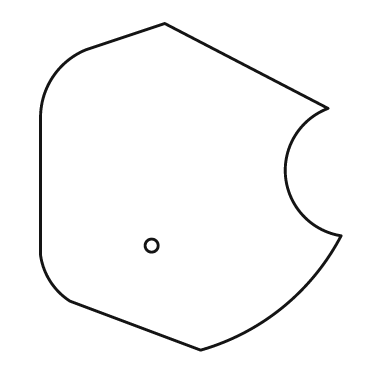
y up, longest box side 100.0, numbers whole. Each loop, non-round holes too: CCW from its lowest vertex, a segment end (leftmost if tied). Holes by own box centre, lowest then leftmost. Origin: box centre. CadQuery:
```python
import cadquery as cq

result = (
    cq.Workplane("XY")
    .moveTo(3.0, -50.0)
    .threePointArc((28.0, -37.0), (46.0, -15.0))
    .threePointArc((29.0, 3.0), (42.0, 24.0))
    .lineTo(-8.0, 50.0)
    .lineTo(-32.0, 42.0)
    .threePointArc((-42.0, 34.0), (-46.0, 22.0))
    .lineTo(-46.0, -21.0)
    .threePointArc((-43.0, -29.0), (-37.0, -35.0))
    .close()
    .moveTo(-12.0, -18.0)
    .circle(2.0)
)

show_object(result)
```